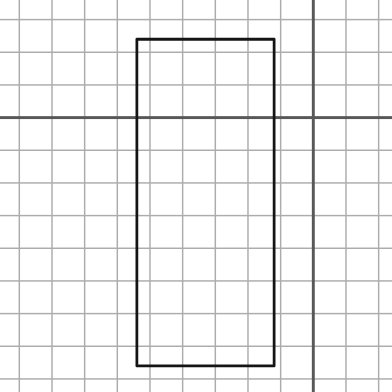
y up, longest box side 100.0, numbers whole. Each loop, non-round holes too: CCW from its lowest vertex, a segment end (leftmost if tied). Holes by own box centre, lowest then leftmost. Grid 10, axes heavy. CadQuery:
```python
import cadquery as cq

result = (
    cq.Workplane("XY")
    .moveTo(-54.0, -76.0)
    .lineTo(-12.0, -76.0)
    .lineTo(-12.0, 24.0)
    .lineTo(-54.0, 24.0)
    .close()
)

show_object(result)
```